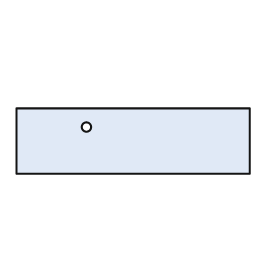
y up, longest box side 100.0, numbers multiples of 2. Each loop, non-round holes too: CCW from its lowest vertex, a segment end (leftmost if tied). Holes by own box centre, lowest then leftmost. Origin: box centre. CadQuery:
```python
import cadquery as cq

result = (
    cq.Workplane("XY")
    .moveTo(-50.0, -14.0)
    .lineTo(50.0, -14.0)
    .lineTo(50.0, 14.0)
    .lineTo(-50.0, 14.0)
    .close()
    .moveTo(-20.0, 6.0)
    .circle(2.0)
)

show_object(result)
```